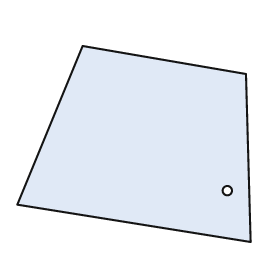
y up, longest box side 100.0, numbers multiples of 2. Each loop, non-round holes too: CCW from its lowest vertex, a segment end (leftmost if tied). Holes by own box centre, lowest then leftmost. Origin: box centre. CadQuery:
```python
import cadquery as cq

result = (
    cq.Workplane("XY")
    .moveTo(50.0, -42.0)
    .lineTo(48.0, 30.0)
    .lineTo(-22.0, 42.0)
    .lineTo(-50.0, -26.0)
    .close()
    .moveTo(40.0, -20.0)
    .circle(2.0)
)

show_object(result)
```